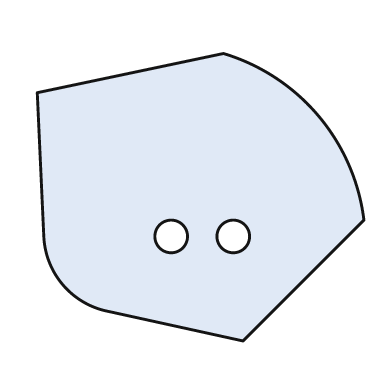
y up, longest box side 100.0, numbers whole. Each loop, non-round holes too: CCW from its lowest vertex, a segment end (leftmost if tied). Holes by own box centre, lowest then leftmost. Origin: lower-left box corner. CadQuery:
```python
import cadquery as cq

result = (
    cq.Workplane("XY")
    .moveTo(63.0, 0.0)
    .lineTo(100.0, 37.0)
    .threePointArc((86.0, 69.0), (57.0, 88.0))
    .lineTo(0.0, 76.0)
    .lineTo(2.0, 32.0)
    .threePointArc((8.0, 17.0), (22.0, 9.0))
    .close()
    .moveTo(41.0, 32.0)
    .circle(5.0)
    .moveTo(60.0, 32.0)
    .circle(5.0)
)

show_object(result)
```